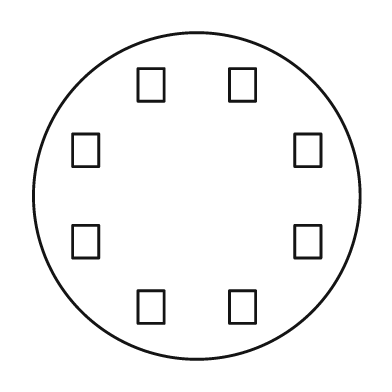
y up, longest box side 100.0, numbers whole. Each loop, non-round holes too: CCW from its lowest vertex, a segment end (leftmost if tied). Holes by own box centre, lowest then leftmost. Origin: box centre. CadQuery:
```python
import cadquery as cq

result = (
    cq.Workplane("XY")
    .moveTo(0.0, 0.0)
    .circle(50.0)
    .moveTo(-18.0, -39.0)
    .lineTo(-10.0, -39.0)
    .lineTo(-10.0, -29.0)
    .lineTo(-18.0, -29.0)
    .close()
    .moveTo(10.0, -39.0)
    .lineTo(18.0, -39.0)
    .lineTo(18.0, -29.0)
    .lineTo(10.0, -29.0)
    .close()
    .moveTo(-38.0, -19.0)
    .lineTo(-30.0, -19.0)
    .lineTo(-30.0, -9.0)
    .lineTo(-38.0, -9.0)
    .close()
    .moveTo(30.0, -19.0)
    .lineTo(38.0, -19.0)
    .lineTo(38.0, -9.0)
    .lineTo(30.0, -9.0)
    .close()
    .moveTo(-38.0, 9.0)
    .lineTo(-30.0, 9.0)
    .lineTo(-30.0, 19.0)
    .lineTo(-38.0, 19.0)
    .close()
    .moveTo(30.0, 9.0)
    .lineTo(38.0, 9.0)
    .lineTo(38.0, 19.0)
    .lineTo(30.0, 19.0)
    .close()
    .moveTo(-18.0, 29.0)
    .lineTo(-10.0, 29.0)
    .lineTo(-10.0, 39.0)
    .lineTo(-18.0, 39.0)
    .close()
    .moveTo(10.0, 29.0)
    .lineTo(18.0, 29.0)
    .lineTo(18.0, 39.0)
    .lineTo(10.0, 39.0)
    .close()
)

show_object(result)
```